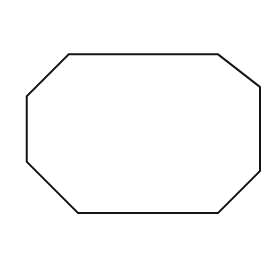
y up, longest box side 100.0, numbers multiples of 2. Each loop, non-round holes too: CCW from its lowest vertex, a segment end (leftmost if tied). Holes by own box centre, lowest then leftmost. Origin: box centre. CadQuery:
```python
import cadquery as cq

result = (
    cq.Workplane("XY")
    .moveTo(-28.0, -34.0)
    .lineTo(32.0, -34.0)
    .lineTo(50.0, -16.0)
    .lineTo(50.0, 20.0)
    .lineTo(32.0, 34.0)
    .lineTo(-32.0, 34.0)
    .lineTo(-50.0, 16.0)
    .lineTo(-50.0, -12.0)
    .close()
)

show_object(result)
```